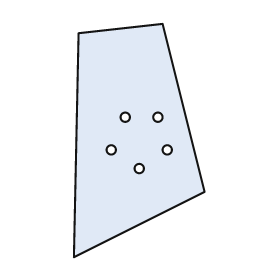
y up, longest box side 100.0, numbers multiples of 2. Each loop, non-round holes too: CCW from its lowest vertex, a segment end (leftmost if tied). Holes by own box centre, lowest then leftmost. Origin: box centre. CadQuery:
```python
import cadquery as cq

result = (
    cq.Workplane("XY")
    .moveTo(-28.0, -50.0)
    .lineTo(28.0, -22.0)
    .lineTo(10.0, 50.0)
    .lineTo(-26.0, 46.0)
    .close()
    .moveTo(0.0, -12.0)
    .circle(2.0)
    .moveTo(-12.0, -4.0)
    .circle(2.0)
    .moveTo(12.0, -4.0)
    .circle(2.0)
    .moveTo(-6.0, 10.0)
    .circle(2.0)
    .moveTo(8.0, 10.0)
    .circle(2.0)
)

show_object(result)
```